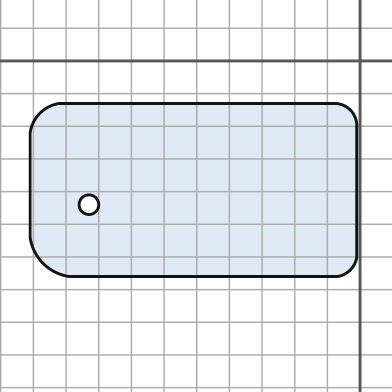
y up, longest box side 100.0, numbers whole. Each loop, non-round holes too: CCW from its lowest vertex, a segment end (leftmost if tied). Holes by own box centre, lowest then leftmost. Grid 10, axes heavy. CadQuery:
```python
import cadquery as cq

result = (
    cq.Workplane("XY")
    .moveTo(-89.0, -66.0)
    .lineTo(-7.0, -66.0)
    .threePointArc((-3.0, -64.0), (-1.0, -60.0))
    .lineTo(-1.0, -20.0)
    .threePointArc((-3.0, -15.0), (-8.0, -13.0))
    .lineTo(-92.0, -13.0)
    .threePointArc((-98.0, -16.0), (-101.0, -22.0))
    .lineTo(-101.0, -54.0)
    .threePointArc((-97.0, -62.0), (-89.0, -66.0))
    .close()
    .moveTo(-83.0, -44.0)
    .circle(3.0)
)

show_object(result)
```